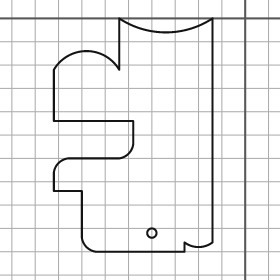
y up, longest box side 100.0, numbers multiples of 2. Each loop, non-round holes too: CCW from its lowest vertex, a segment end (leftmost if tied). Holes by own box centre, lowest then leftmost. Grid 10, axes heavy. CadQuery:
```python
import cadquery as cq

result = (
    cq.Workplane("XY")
    .moveTo(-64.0, -100.0)
    .lineTo(-26.0, -100.0)
    .lineTo(-26.0, -96.0)
    .threePointArc((-20.0, -98.0), (-14.0, -96.0))
    .lineTo(-14.0, 0.0)
    .threePointArc((-34.0, -6.0), (-54.0, 0.0))
    .lineTo(-54.0, -22.0)
    .threePointArc((-68.0, -14.0), (-82.0, -22.0))
    .lineTo(-82.0, -44.0)
    .lineTo(-48.0, -44.0)
    .lineTo(-48.0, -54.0)
    .threePointArc((-50.0, -58.0), (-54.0, -60.0))
    .lineTo(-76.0, -60.0)
    .threePointArc((-80.0, -62.0), (-82.0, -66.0))
    .lineTo(-82.0, -74.0)
    .lineTo(-70.0, -74.0)
    .lineTo(-70.0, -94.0)
    .threePointArc((-68.0, -98.0), (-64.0, -100.0))
    .close()
    .moveTo(-40.0, -92.0)
    .circle(2.0)
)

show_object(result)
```